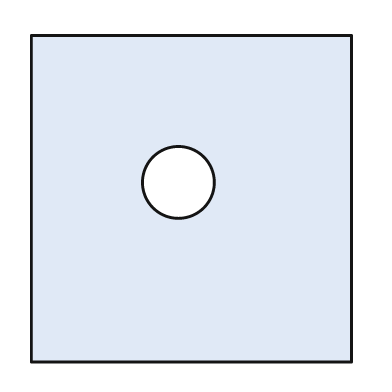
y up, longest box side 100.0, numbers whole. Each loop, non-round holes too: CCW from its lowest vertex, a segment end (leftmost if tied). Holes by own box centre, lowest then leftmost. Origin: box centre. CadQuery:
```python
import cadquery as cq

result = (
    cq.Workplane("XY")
    .moveTo(-49.0, -50.0)
    .lineTo(49.0, -50.0)
    .lineTo(49.0, 50.0)
    .lineTo(-49.0, 50.0)
    .close()
    .moveTo(-4.0, 5.0)
    .circle(11.0)
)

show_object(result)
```